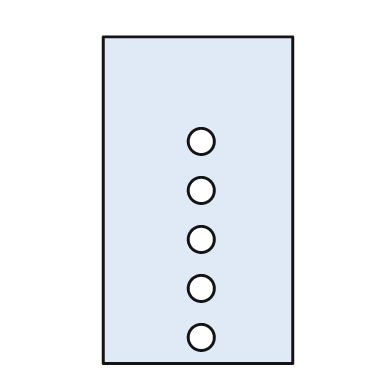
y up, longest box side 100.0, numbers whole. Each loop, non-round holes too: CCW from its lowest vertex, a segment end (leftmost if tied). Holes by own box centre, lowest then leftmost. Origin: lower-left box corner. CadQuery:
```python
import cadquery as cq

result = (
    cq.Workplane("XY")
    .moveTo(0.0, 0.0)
    .lineTo(58.0, 0.0)
    .lineTo(58.0, 100.0)
    .lineTo(0.0, 100.0)
    .close()
    .moveTo(30.0, 8.0)
    .circle(4.0)
    .moveTo(30.0, 23.0)
    .circle(4.0)
    .moveTo(30.0, 38.0)
    .circle(4.0)
    .moveTo(30.0, 53.0)
    .circle(4.0)
    .moveTo(30.0, 68.0)
    .circle(4.0)
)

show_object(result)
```